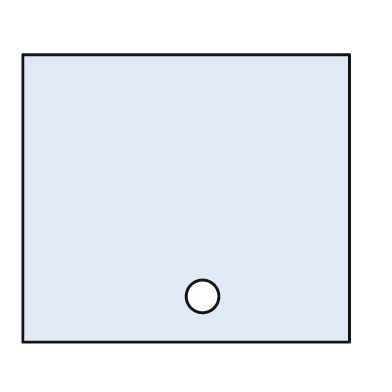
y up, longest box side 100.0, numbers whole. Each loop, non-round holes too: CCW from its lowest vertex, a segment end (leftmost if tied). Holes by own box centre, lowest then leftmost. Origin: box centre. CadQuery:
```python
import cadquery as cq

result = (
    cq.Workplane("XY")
    .moveTo(-50.0, -44.0)
    .lineTo(50.0, -44.0)
    .lineTo(50.0, 44.0)
    .lineTo(-50.0, 44.0)
    .close()
    .moveTo(5.0, -30.0)
    .circle(5.0)
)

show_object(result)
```